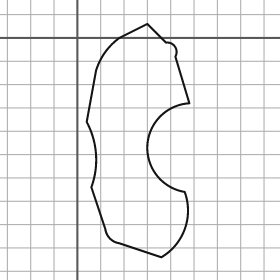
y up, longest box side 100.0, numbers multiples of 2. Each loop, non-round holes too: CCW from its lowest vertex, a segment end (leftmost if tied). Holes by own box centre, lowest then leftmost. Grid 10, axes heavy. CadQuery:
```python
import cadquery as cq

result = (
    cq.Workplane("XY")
    .moveTo(36.0, -94.0)
    .threePointArc((46.0, -82.0), (46.0, -66.0))
    .threePointArc((30.0, -46.0), (48.0, -28.0))
    .lineTo(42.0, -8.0)
    .threePointArc((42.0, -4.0), (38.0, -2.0))
    .lineTo(30.0, 6.0)
    .lineTo(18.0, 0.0)
    .threePointArc((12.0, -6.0), (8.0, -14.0))
    .lineTo(4.0, -36.0)
    .threePointArc((8.0, -50.0), (6.0, -64.0))
    .lineTo(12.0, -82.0)
    .threePointArc((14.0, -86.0), (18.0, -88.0))
    .close()
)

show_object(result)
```